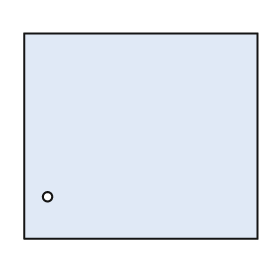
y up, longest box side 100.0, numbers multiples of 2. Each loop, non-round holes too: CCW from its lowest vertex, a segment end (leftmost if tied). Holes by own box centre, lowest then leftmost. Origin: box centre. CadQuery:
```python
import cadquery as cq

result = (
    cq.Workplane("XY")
    .moveTo(-50.0, -44.0)
    .lineTo(50.0, -44.0)
    .lineTo(50.0, 44.0)
    .lineTo(-50.0, 44.0)
    .close()
    .moveTo(-40.0, -26.0)
    .circle(2.0)
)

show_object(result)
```